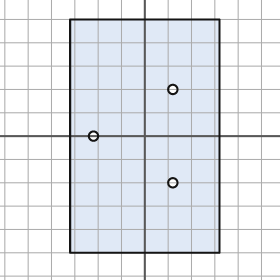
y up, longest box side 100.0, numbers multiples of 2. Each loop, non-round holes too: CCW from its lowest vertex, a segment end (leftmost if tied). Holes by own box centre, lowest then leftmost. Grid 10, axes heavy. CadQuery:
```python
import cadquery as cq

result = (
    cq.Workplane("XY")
    .moveTo(-32.0, -50.0)
    .lineTo(32.0, -50.0)
    .lineTo(32.0, 50.0)
    .lineTo(-32.0, 50.0)
    .close()
    .moveTo(12.0, -20.0)
    .circle(2.0)
    .moveTo(-22.0, 0.0)
    .circle(2.0)
    .moveTo(12.0, 20.0)
    .circle(2.0)
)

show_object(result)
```